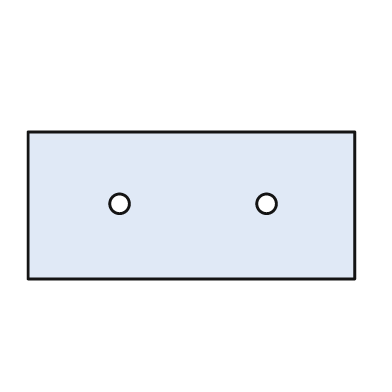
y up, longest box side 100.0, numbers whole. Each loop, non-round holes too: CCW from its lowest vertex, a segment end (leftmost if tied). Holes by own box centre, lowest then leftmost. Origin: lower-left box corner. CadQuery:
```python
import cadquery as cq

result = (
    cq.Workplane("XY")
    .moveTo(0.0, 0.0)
    .lineTo(100.0, 0.0)
    .lineTo(100.0, 45.0)
    .lineTo(0.0, 45.0)
    .close()
    .moveTo(28.0, 23.0)
    .circle(3.0)
    .moveTo(73.0, 23.0)
    .circle(3.0)
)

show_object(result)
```